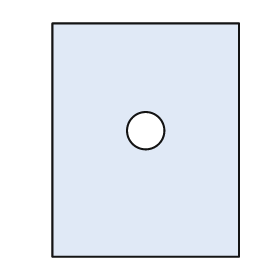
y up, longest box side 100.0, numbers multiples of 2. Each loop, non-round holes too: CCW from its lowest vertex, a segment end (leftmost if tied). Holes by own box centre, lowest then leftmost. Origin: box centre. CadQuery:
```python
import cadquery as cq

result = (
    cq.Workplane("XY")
    .moveTo(-40.0, -50.0)
    .lineTo(40.0, -50.0)
    .lineTo(40.0, 50.0)
    .lineTo(-40.0, 50.0)
    .close()
    .moveTo(0.0, 4.0)
    .circle(8.0)
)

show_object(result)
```